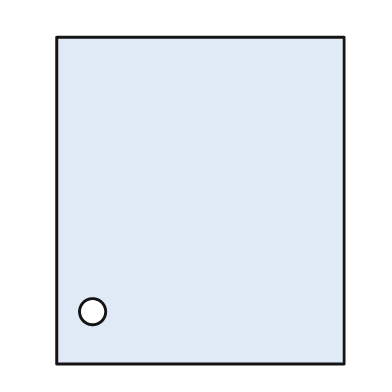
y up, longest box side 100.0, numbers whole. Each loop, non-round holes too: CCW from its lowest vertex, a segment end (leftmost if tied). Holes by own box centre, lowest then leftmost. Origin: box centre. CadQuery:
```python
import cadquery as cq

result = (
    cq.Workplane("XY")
    .moveTo(-44.0, -50.0)
    .lineTo(44.0, -50.0)
    .lineTo(44.0, 50.0)
    .lineTo(-44.0, 50.0)
    .close()
    .moveTo(-33.0, -34.0)
    .circle(4.0)
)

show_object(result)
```